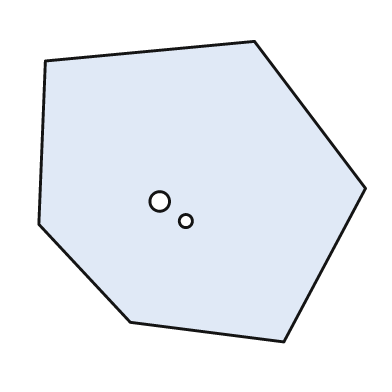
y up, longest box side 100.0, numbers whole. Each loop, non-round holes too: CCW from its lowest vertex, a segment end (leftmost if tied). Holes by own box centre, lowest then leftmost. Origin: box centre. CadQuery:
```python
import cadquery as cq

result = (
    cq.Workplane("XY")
    .moveTo(25.0, -46.0)
    .lineTo(50.0, 1.0)
    .lineTo(16.0, 46.0)
    .lineTo(-48.0, 40.0)
    .lineTo(-50.0, -10.0)
    .lineTo(-22.0, -40.0)
    .close()
    .moveTo(-5.0, -9.0)
    .circle(2.0)
    .moveTo(-13.0, -3.0)
    .circle(3.0)
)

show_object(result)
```